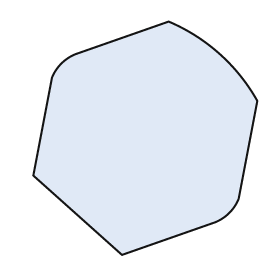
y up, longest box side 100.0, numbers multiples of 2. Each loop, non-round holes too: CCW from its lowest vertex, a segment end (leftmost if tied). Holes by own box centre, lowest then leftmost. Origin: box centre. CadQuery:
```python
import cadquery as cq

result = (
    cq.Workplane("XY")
    .moveTo(-10.0, -50.0)
    .lineTo(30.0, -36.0)
    .threePointArc((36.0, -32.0), (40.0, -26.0))
    .lineTo(48.0, 16.0)
    .threePointArc((32.0, 36.0), (10.0, 50.0))
    .lineTo(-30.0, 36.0)
    .threePointArc((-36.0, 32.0), (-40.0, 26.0))
    .lineTo(-48.0, -16.0)
    .close()
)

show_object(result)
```